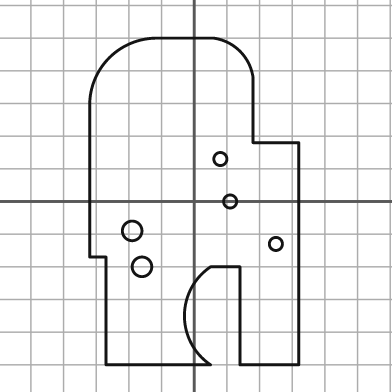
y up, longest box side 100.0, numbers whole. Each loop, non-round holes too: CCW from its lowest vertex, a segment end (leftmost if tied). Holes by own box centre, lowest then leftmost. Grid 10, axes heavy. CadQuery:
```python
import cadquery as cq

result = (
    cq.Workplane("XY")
    .moveTo(-27.0, -50.0)
    .lineTo(5.0, -50.0)
    .threePointArc((-3.0, -35.0), (5.0, -20.0))
    .lineTo(14.0, -20.0)
    .lineTo(14.0, -50.0)
    .lineTo(32.0, -50.0)
    .lineTo(32.0, 18.0)
    .lineTo(18.0, 18.0)
    .lineTo(18.0, 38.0)
    .threePointArc((14.0, 46.0), (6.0, 50.0))
    .lineTo(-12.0, 50.0)
    .threePointArc((-26.0, 44.0), (-32.0, 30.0))
    .lineTo(-32.0, -17.0)
    .lineTo(-27.0, -17.0)
    .close()
    .moveTo(-16.0, -20.0)
    .circle(3.0)
    .moveTo(25.0, -13.0)
    .circle(2.0)
    .moveTo(-19.0, -9.0)
    .circle(3.0)
    .moveTo(11.0, 0.0)
    .circle(2.0)
    .moveTo(8.0, 13.0)
    .circle(2.0)
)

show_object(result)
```